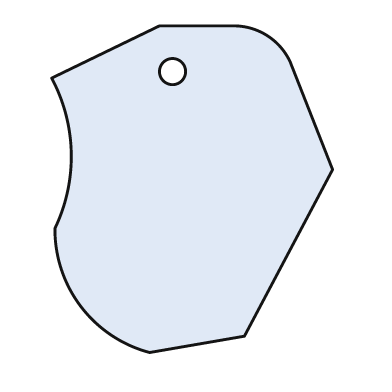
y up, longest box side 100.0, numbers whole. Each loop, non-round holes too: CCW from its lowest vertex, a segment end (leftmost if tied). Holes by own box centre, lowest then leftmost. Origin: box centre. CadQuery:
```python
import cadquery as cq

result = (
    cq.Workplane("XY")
    .moveTo(-13.0, -50.0)
    .lineTo(16.0, -45.0)
    .lineTo(43.0, 6.0)
    .lineTo(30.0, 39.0)
    .threePointArc((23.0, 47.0), (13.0, 50.0))
    .lineTo(-10.0, 50.0)
    .lineTo(-43.0, 34.0)
    .threePointArc((-37.0, 11.0), (-42.0, -12.0))
    .threePointArc((-34.0, -36.0), (-13.0, -50.0))
    .close()
    .moveTo(-6.0, 36.0)
    .circle(4.0)
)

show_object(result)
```